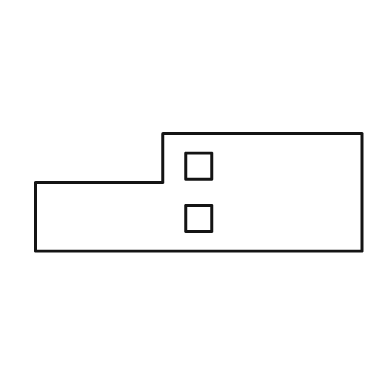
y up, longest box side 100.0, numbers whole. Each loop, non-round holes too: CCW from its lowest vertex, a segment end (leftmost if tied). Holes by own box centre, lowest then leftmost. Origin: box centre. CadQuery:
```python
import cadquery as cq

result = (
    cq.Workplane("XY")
    .moveTo(-50.0, -18.0)
    .lineTo(50.0, -18.0)
    .lineTo(50.0, 18.0)
    .lineTo(-11.0, 18.0)
    .lineTo(-11.0, 3.0)
    .lineTo(-50.0, 3.0)
    .close()
    .moveTo(-4.0, -12.0)
    .lineTo(4.0, -12.0)
    .lineTo(4.0, -4.0)
    .lineTo(-4.0, -4.0)
    .close()
    .moveTo(-4.0, 4.0)
    .lineTo(4.0, 4.0)
    .lineTo(4.0, 12.0)
    .lineTo(-4.0, 12.0)
    .close()
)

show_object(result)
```